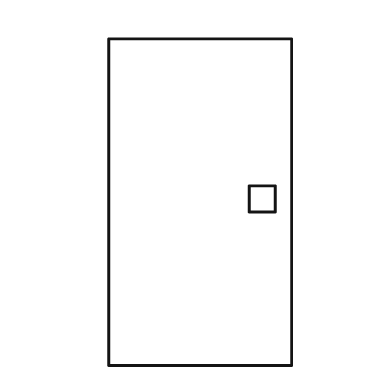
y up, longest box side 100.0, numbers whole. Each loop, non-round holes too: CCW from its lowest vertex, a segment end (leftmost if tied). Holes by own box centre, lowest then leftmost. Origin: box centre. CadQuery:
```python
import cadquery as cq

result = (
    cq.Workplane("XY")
    .moveTo(-28.0, -50.0)
    .lineTo(28.0, -50.0)
    .lineTo(28.0, 50.0)
    .lineTo(-28.0, 50.0)
    .close()
    .moveTo(15.0, -3.0)
    .lineTo(23.0, -3.0)
    .lineTo(23.0, 5.0)
    .lineTo(15.0, 5.0)
    .close()
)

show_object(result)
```